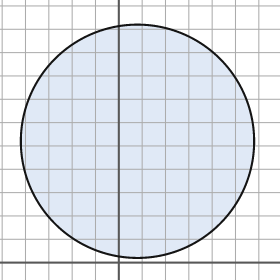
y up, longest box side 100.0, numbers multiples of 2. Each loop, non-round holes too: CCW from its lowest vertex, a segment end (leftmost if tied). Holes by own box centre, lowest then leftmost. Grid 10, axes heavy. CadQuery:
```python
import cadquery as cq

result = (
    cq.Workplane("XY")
    .moveTo(8.0, 52.0)
    .circle(50.0)
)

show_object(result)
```